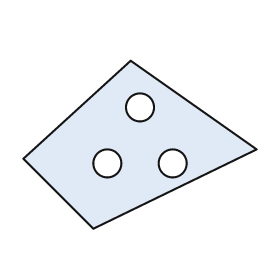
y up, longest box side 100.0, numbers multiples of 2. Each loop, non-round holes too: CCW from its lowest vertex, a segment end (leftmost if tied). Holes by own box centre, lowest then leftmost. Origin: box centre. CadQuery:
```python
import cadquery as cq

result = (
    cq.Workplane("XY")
    .moveTo(-20.0, -36.0)
    .lineTo(50.0, -2.0)
    .lineTo(-4.0, 36.0)
    .lineTo(-50.0, -6.0)
    .close()
    .moveTo(-14.0, -8.0)
    .circle(6.0)
    .moveTo(14.0, -8.0)
    .circle(6.0)
    .moveTo(0.0, 16.0)
    .circle(6.0)
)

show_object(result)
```